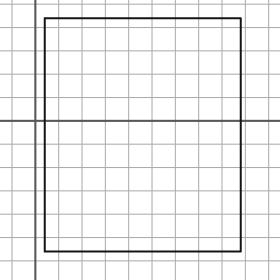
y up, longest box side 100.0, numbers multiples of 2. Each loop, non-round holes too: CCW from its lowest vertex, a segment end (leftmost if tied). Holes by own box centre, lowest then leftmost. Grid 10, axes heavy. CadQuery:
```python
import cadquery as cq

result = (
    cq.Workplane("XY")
    .moveTo(4.0, -56.0)
    .lineTo(88.0, -56.0)
    .lineTo(88.0, 44.0)
    .lineTo(4.0, 44.0)
    .close()
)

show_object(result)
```